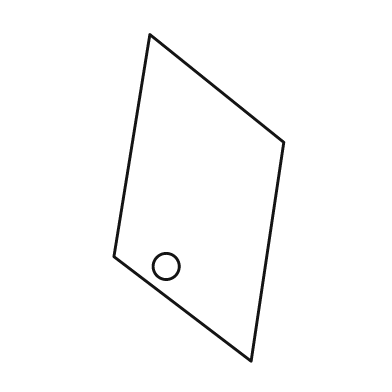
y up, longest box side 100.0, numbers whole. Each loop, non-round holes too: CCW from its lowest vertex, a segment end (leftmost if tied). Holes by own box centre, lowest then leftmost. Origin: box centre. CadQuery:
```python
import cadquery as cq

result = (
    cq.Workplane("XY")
    .moveTo(16.0, -50.0)
    .lineTo(26.0, 17.0)
    .lineTo(-15.0, 50.0)
    .lineTo(-26.0, -18.0)
    .close()
    .moveTo(-10.0, -21.0)
    .circle(4.0)
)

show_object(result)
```